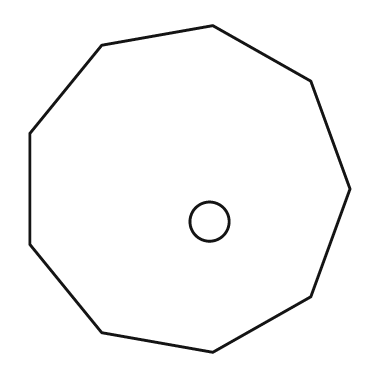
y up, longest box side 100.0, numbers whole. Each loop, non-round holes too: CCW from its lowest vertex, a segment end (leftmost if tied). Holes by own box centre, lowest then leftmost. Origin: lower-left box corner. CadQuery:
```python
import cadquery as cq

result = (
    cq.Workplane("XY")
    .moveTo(56.0, 0.0)
    .lineTo(86.0, 17.0)
    .lineTo(98.0, 50.0)
    .lineTo(86.0, 83.0)
    .lineTo(56.0, 100.0)
    .lineTo(22.0, 94.0)
    .lineTo(0.0, 67.0)
    .lineTo(0.0, 33.0)
    .lineTo(22.0, 6.0)
    .close()
    .moveTo(55.0, 40.0)
    .circle(6.0)
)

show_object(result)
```